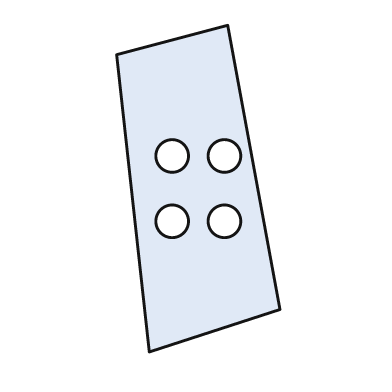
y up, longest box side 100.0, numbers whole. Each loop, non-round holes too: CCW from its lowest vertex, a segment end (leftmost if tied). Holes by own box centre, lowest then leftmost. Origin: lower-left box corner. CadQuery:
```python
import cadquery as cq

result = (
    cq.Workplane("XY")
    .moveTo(10.0, 0.0)
    .lineTo(50.0, 13.0)
    .lineTo(34.0, 100.0)
    .lineTo(0.0, 91.0)
    .close()
    .moveTo(17.0, 40.0)
    .circle(5.0)
    .moveTo(33.0, 40.0)
    .circle(5.0)
    .moveTo(17.0, 60.0)
    .circle(5.0)
    .moveTo(33.0, 60.0)
    .circle(5.0)
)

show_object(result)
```